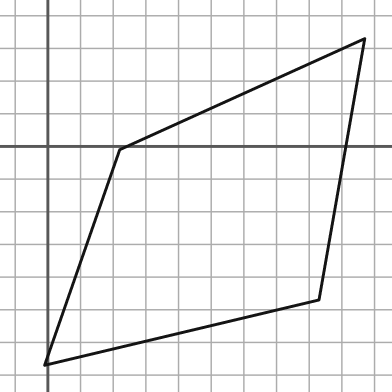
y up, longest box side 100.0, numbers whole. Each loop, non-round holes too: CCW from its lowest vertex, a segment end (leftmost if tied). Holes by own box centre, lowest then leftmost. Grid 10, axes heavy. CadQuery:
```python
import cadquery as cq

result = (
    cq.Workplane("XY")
    .moveTo(-1.0, -67.0)
    .lineTo(83.0, -47.0)
    .lineTo(97.0, 33.0)
    .lineTo(22.0, -1.0)
    .close()
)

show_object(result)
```